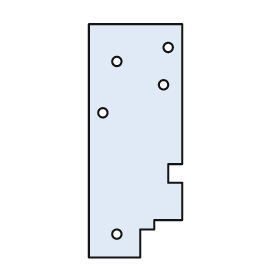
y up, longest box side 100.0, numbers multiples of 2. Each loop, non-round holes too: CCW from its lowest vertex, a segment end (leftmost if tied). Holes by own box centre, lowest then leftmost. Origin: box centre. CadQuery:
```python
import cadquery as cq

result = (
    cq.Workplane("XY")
    .moveTo(-20.0, -50.0)
    .lineTo(2.0, -50.0)
    .lineTo(2.0, -38.0)
    .lineTo(8.0, -38.0)
    .lineTo(8.0, -34.0)
    .lineTo(20.0, -34.0)
    .lineTo(20.0, -18.0)
    .lineTo(14.0, -18.0)
    .lineTo(14.0, -10.0)
    .lineTo(20.0, -10.0)
    .lineTo(20.0, 50.0)
    .lineTo(-20.0, 50.0)
    .close()
    .moveTo(-8.0, -40.0)
    .circle(2.0)
    .moveTo(-14.0, 12.0)
    .circle(2.0)
    .moveTo(12.0, 24.0)
    .circle(2.0)
    .moveTo(-8.0, 34.0)
    .circle(2.0)
    .moveTo(14.0, 40.0)
    .circle(2.0)
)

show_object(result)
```